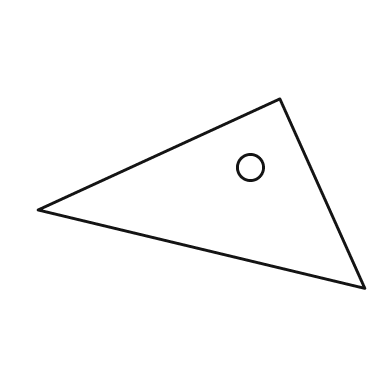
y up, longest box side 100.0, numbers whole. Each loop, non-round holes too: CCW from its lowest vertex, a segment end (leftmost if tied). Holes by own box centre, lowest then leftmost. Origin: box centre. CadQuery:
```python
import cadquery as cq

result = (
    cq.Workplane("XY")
    .moveTo(50.0, -29.0)
    .lineTo(24.0, 29.0)
    .lineTo(-50.0, -5.0)
    .close()
    .moveTo(15.0, 8.0)
    .circle(4.0)
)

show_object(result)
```